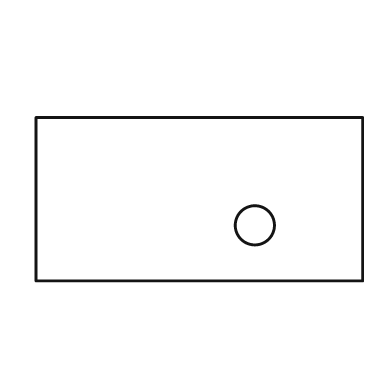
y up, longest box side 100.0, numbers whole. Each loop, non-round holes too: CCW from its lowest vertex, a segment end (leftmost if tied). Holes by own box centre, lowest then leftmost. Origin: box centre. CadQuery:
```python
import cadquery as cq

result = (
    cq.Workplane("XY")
    .moveTo(-50.0, -25.0)
    .lineTo(50.0, -25.0)
    .lineTo(50.0, 25.0)
    .lineTo(-50.0, 25.0)
    .close()
    .moveTo(17.0, -8.0)
    .circle(6.0)
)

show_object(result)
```